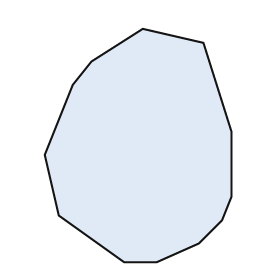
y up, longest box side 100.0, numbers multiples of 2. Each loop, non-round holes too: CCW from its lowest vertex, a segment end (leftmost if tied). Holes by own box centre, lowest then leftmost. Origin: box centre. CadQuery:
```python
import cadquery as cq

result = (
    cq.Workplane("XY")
    .moveTo(-6.0, -50.0)
    .lineTo(8.0, -50.0)
    .lineTo(26.0, -42.0)
    .lineTo(36.0, -32.0)
    .lineTo(40.0, -22.0)
    .lineTo(40.0, 6.0)
    .lineTo(28.0, 44.0)
    .lineTo(2.0, 50.0)
    .lineTo(-20.0, 36.0)
    .lineTo(-28.0, 26.0)
    .lineTo(-40.0, -4.0)
    .lineTo(-34.0, -30.0)
    .close()
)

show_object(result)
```